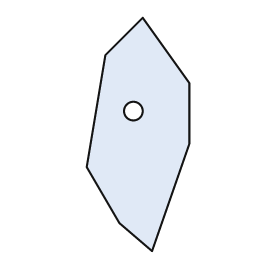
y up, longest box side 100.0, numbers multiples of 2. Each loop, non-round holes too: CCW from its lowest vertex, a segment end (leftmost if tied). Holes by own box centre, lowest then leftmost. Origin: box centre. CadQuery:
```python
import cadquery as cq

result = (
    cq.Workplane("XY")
    .moveTo(6.0, -50.0)
    .lineTo(22.0, -4.0)
    .lineTo(22.0, 22.0)
    .lineTo(2.0, 50.0)
    .lineTo(-14.0, 34.0)
    .lineTo(-22.0, -14.0)
    .lineTo(-8.0, -38.0)
    .close()
    .moveTo(-2.0, 10.0)
    .circle(4.0)
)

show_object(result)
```